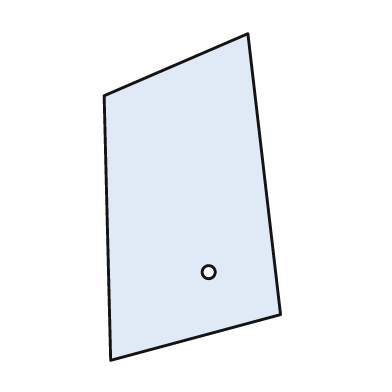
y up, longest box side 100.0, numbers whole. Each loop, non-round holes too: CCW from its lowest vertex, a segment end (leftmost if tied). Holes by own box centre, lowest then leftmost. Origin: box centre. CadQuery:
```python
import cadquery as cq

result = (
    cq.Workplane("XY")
    .moveTo(-25.0, -50.0)
    .lineTo(27.0, -36.0)
    .lineTo(17.0, 50.0)
    .lineTo(-27.0, 31.0)
    .close()
    .moveTo(5.0, -23.0)
    .circle(2.0)
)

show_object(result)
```